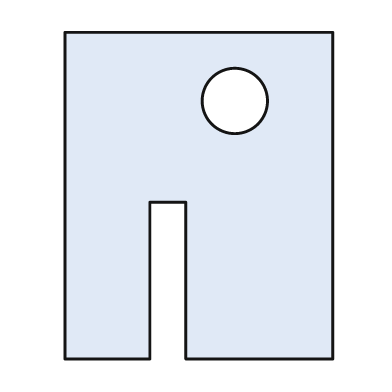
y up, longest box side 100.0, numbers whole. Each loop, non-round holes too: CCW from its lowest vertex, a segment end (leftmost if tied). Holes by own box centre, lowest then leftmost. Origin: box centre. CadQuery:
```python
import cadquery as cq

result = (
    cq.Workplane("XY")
    .moveTo(-41.0, -50.0)
    .lineTo(-15.0, -50.0)
    .lineTo(-15.0, -2.0)
    .lineTo(-4.0, -2.0)
    .lineTo(-4.0, -50.0)
    .lineTo(41.0, -50.0)
    .lineTo(41.0, 50.0)
    .lineTo(-41.0, 50.0)
    .close()
    .moveTo(11.0, 29.0)
    .circle(10.0)
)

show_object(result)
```